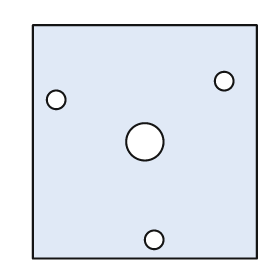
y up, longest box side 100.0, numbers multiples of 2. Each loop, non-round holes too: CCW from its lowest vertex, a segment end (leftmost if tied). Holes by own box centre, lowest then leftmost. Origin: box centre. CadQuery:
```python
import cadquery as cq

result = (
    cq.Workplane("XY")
    .moveTo(-48.0, -50.0)
    .lineTo(48.0, -50.0)
    .lineTo(48.0, 50.0)
    .lineTo(-48.0, 50.0)
    .close()
    .moveTo(4.0, -42.0)
    .circle(4.0)
    .moveTo(0.0, 0.0)
    .circle(8.0)
    .moveTo(-38.0, 18.0)
    .circle(4.0)
    .moveTo(34.0, 26.0)
    .circle(4.0)
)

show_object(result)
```